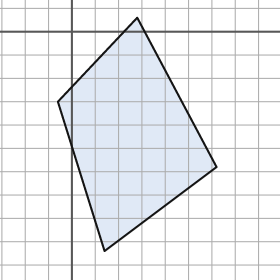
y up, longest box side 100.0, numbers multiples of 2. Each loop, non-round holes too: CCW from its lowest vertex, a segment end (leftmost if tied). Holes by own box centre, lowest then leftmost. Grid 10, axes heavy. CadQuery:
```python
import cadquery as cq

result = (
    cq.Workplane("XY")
    .moveTo(14.0, -94.0)
    .lineTo(62.0, -58.0)
    .lineTo(28.0, 6.0)
    .lineTo(-6.0, -30.0)
    .close()
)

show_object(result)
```